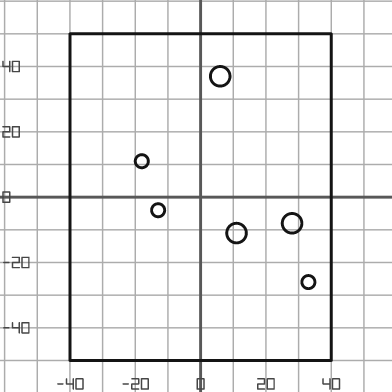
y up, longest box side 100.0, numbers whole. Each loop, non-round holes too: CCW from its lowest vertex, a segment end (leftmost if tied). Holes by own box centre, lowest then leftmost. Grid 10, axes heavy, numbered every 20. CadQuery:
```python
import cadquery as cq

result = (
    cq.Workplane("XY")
    .moveTo(-40.0, -50.0)
    .lineTo(40.0, -50.0)
    .lineTo(40.0, 50.0)
    .lineTo(-40.0, 50.0)
    .close()
    .moveTo(33.0, -26.0)
    .circle(2.0)
    .moveTo(11.0, -11.0)
    .circle(3.0)
    .moveTo(28.0, -8.0)
    .circle(3.0)
    .moveTo(-13.0, -4.0)
    .circle(2.0)
    .moveTo(-18.0, 11.0)
    .circle(2.0)
    .moveTo(6.0, 37.0)
    .circle(3.0)
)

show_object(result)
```